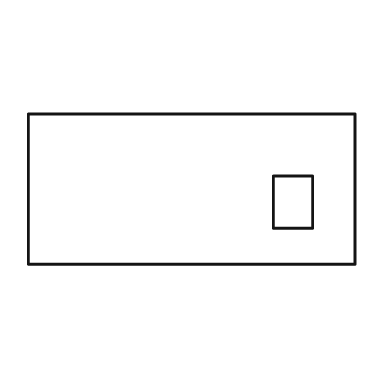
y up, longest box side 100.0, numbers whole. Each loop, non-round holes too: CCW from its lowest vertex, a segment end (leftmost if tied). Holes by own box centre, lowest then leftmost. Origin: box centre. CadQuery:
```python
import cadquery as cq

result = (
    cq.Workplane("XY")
    .moveTo(-50.0, -23.0)
    .lineTo(50.0, -23.0)
    .lineTo(50.0, 23.0)
    .lineTo(-50.0, 23.0)
    .close()
    .moveTo(25.0, -12.0)
    .lineTo(37.0, -12.0)
    .lineTo(37.0, 4.0)
    .lineTo(25.0, 4.0)
    .close()
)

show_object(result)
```